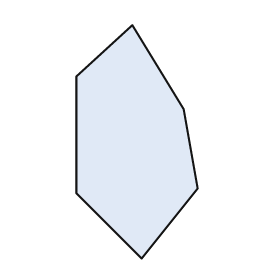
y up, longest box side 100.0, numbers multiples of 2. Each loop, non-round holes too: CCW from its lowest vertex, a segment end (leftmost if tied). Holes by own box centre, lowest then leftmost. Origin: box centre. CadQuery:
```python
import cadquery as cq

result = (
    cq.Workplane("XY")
    .moveTo(2.0, -50.0)
    .lineTo(26.0, -20.0)
    .lineTo(20.0, 14.0)
    .lineTo(-2.0, 50.0)
    .lineTo(-26.0, 28.0)
    .lineTo(-26.0, -22.0)
    .close()
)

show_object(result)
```